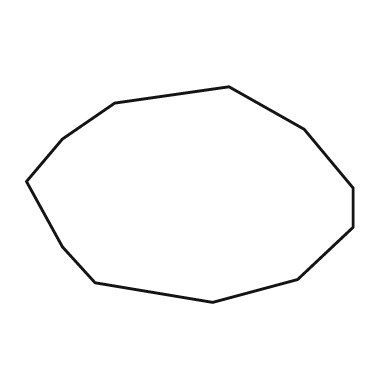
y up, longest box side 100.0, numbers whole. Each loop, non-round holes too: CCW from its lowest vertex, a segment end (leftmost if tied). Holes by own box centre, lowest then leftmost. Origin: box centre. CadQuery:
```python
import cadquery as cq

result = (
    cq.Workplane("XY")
    .moveTo(7.0, -33.0)
    .lineTo(33.0, -26.0)
    .lineTo(50.0, -10.0)
    .lineTo(50.0, 2.0)
    .lineTo(35.0, 20.0)
    .lineTo(12.0, 33.0)
    .lineTo(-23.0, 28.0)
    .lineTo(-39.0, 17.0)
    .lineTo(-50.0, 4.0)
    .lineTo(-39.0, -16.0)
    .lineTo(-29.0, -27.0)
    .close()
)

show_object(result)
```